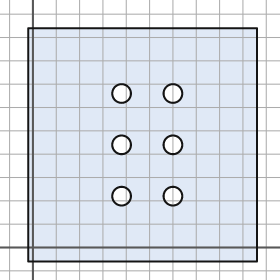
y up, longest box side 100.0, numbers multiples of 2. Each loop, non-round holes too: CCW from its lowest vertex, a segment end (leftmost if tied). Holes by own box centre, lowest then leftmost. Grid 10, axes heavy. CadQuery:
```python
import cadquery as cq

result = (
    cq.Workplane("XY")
    .moveTo(-2.0, -6.0)
    .lineTo(96.0, -6.0)
    .lineTo(96.0, 94.0)
    .lineTo(-2.0, 94.0)
    .close()
    .moveTo(38.0, 22.0)
    .circle(4.0)
    .moveTo(60.0, 22.0)
    .circle(4.0)
    .moveTo(38.0, 44.0)
    .circle(4.0)
    .moveTo(60.0, 44.0)
    .circle(4.0)
    .moveTo(38.0, 66.0)
    .circle(4.0)
    .moveTo(60.0, 66.0)
    .circle(4.0)
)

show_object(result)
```